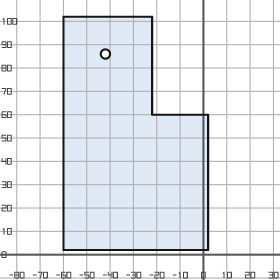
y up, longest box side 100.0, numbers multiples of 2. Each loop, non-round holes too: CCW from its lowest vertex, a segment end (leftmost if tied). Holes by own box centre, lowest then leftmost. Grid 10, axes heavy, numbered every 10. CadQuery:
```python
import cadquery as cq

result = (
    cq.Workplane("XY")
    .moveTo(-60.0, 2.0)
    .lineTo(2.0, 2.0)
    .lineTo(2.0, 60.0)
    .lineTo(-22.0, 60.0)
    .lineTo(-22.0, 102.0)
    .lineTo(-60.0, 102.0)
    .close()
    .moveTo(-42.0, 86.0)
    .circle(2.0)
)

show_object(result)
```